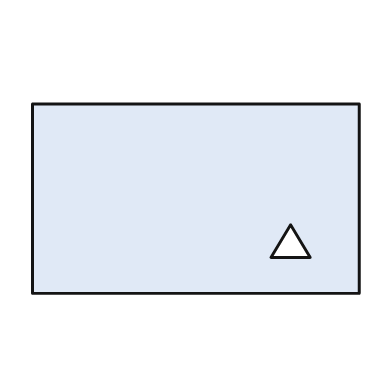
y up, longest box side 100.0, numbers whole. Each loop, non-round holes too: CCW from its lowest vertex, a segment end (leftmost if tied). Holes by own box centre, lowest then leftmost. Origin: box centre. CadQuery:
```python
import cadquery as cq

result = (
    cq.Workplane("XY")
    .moveTo(-50.0, -29.0)
    .lineTo(50.0, -29.0)
    .lineTo(50.0, 29.0)
    .lineTo(-50.0, 29.0)
    .close()
    .moveTo(23.0, -18.0)
    .lineTo(35.0, -18.0)
    .lineTo(29.0, -8.0)
    .close()
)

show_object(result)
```